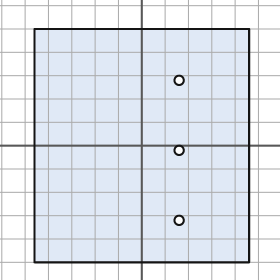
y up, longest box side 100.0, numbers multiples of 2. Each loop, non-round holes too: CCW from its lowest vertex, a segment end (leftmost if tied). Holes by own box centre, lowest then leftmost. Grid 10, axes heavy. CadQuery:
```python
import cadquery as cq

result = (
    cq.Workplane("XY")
    .moveTo(-46.0, -50.0)
    .lineTo(46.0, -50.0)
    .lineTo(46.0, 50.0)
    .lineTo(-46.0, 50.0)
    .close()
    .moveTo(16.0, -32.0)
    .circle(2.0)
    .moveTo(16.0, -2.0)
    .circle(2.0)
    .moveTo(16.0, 28.0)
    .circle(2.0)
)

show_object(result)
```